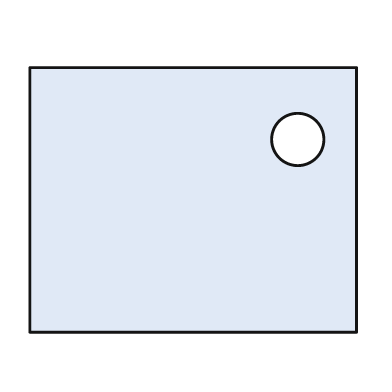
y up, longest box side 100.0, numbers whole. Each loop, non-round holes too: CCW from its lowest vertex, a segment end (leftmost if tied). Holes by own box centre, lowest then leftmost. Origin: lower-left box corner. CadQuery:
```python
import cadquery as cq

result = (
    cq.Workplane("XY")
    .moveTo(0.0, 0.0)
    .lineTo(100.0, 0.0)
    .lineTo(100.0, 81.0)
    .lineTo(0.0, 81.0)
    .close()
    .moveTo(82.0, 59.0)
    .circle(8.0)
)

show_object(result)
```